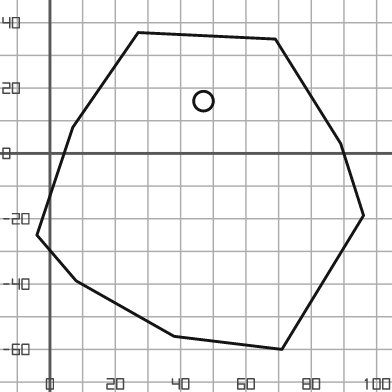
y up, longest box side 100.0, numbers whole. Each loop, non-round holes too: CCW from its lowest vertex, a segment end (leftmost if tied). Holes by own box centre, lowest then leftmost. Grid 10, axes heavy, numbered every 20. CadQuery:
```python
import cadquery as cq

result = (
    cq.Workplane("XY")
    .moveTo(71.0, -60.0)
    .lineTo(96.0, -19.0)
    .lineTo(89.0, 3.0)
    .lineTo(69.0, 35.0)
    .lineTo(27.0, 37.0)
    .lineTo(7.0, 8.0)
    .lineTo(-4.0, -25.0)
    .lineTo(8.0, -39.0)
    .lineTo(38.0, -56.0)
    .close()
    .moveTo(47.0, 16.0)
    .circle(3.0)
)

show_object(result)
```